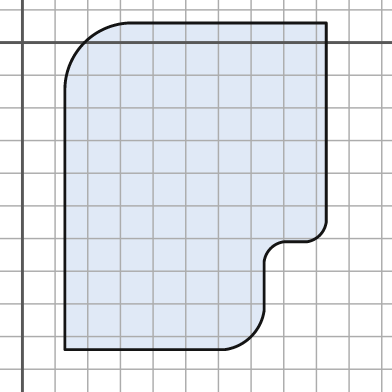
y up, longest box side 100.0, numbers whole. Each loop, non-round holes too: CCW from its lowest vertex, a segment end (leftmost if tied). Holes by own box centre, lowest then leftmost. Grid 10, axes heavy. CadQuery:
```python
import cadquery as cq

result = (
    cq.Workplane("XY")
    .moveTo(13.0, -94.0)
    .lineTo(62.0, -94.0)
    .threePointArc((70.0, -90.0), (74.0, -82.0))
    .lineTo(74.0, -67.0)
    .threePointArc((76.0, -63.0), (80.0, -61.0))
    .lineTo(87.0, -61.0)
    .threePointArc((91.0, -59.0), (93.0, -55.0))
    .lineTo(93.0, 6.0)
    .lineTo(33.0, 6.0)
    .threePointArc((19.0, 0.0), (13.0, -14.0))
    .close()
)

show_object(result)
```